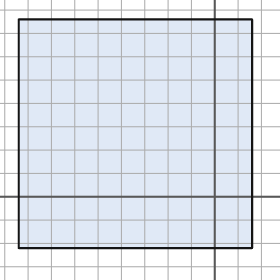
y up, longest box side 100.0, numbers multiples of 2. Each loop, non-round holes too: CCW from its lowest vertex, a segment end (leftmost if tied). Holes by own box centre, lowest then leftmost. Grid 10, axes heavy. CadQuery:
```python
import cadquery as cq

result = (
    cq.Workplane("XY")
    .moveTo(-84.0, -22.0)
    .lineTo(16.0, -22.0)
    .lineTo(16.0, 76.0)
    .lineTo(-84.0, 76.0)
    .close()
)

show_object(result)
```